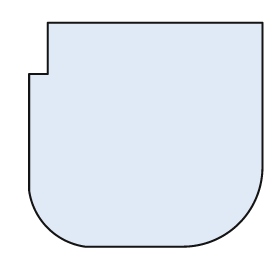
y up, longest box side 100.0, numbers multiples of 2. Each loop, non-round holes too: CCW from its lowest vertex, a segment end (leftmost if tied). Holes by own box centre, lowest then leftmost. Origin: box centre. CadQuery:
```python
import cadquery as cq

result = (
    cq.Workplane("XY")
    .moveTo(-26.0, -48.0)
    .lineTo(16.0, -48.0)
    .threePointArc((40.0, -38.0), (50.0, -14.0))
    .lineTo(50.0, 48.0)
    .lineTo(-42.0, 48.0)
    .lineTo(-42.0, 26.0)
    .lineTo(-50.0, 26.0)
    .lineTo(-50.0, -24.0)
    .threePointArc((-42.0, -40.0), (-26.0, -48.0))
    .close()
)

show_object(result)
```